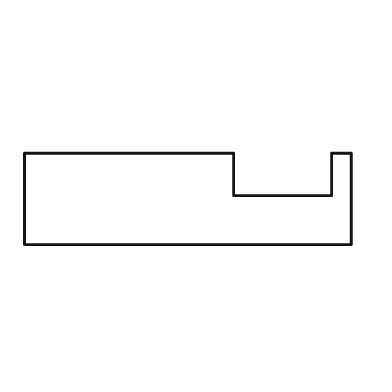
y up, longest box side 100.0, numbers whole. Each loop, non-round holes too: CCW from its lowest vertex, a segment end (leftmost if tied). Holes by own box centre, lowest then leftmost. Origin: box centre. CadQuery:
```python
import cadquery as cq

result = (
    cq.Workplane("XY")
    .moveTo(-50.0, -14.0)
    .lineTo(50.0, -14.0)
    .lineTo(50.0, 14.0)
    .lineTo(44.0, 14.0)
    .lineTo(44.0, 1.0)
    .lineTo(14.0, 1.0)
    .lineTo(14.0, 14.0)
    .lineTo(-50.0, 14.0)
    .close()
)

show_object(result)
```